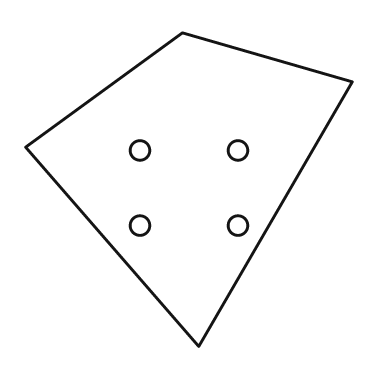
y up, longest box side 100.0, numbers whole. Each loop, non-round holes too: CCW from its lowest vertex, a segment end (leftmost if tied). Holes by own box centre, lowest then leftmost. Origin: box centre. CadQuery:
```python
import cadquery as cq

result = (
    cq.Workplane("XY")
    .moveTo(3.0, -48.0)
    .lineTo(50.0, 33.0)
    .lineTo(-2.0, 48.0)
    .lineTo(-50.0, 13.0)
    .close()
    .moveTo(-15.0, -11.0)
    .circle(3.0)
    .moveTo(15.0, -11.0)
    .circle(3.0)
    .moveTo(-15.0, 12.0)
    .circle(3.0)
    .moveTo(15.0, 12.0)
    .circle(3.0)
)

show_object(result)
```